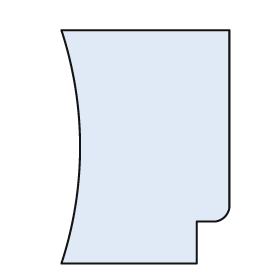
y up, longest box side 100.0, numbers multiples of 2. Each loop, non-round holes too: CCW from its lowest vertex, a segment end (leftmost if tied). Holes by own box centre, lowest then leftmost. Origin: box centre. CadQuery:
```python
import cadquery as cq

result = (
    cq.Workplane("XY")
    .moveTo(-36.0, -50.0)
    .lineTo(22.0, -50.0)
    .lineTo(22.0, -32.0)
    .lineTo(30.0, -32.0)
    .threePointArc((34.0, -30.0), (36.0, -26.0))
    .lineTo(36.0, 50.0)
    .lineTo(-36.0, 50.0)
    .threePointArc((-28.0, 0.0), (-36.0, -50.0))
    .close()
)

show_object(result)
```